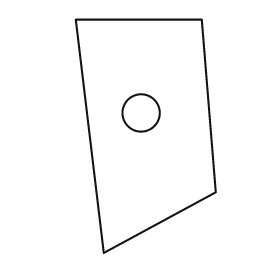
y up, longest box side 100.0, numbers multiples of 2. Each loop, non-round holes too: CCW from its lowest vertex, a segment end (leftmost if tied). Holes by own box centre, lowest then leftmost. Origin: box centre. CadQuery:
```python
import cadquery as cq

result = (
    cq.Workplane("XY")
    .moveTo(-18.0, -50.0)
    .lineTo(30.0, -24.0)
    .lineTo(24.0, 50.0)
    .lineTo(-30.0, 50.0)
    .close()
    .moveTo(-2.0, 10.0)
    .circle(8.0)
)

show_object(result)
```